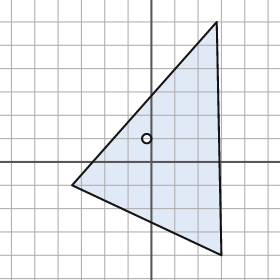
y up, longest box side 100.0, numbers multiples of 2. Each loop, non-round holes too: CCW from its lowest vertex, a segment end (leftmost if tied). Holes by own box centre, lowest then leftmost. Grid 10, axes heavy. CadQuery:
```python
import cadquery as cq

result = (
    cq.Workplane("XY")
    .moveTo(30.0, -40.0)
    .lineTo(28.0, 60.0)
    .lineTo(-34.0, -10.0)
    .close()
    .moveTo(-2.0, 10.0)
    .circle(2.0)
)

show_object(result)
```